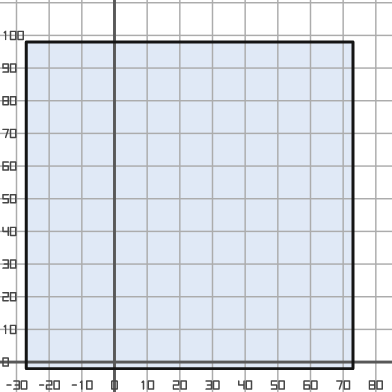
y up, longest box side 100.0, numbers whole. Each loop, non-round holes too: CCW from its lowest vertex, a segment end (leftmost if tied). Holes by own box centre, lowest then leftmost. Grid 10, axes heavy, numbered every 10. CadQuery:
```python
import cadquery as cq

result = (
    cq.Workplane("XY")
    .moveTo(-27.0, -2.0)
    .lineTo(73.0, -2.0)
    .lineTo(73.0, 98.0)
    .lineTo(-27.0, 98.0)
    .close()
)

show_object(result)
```